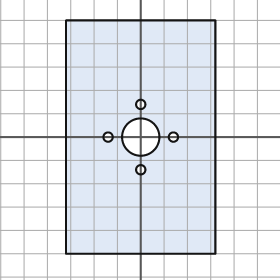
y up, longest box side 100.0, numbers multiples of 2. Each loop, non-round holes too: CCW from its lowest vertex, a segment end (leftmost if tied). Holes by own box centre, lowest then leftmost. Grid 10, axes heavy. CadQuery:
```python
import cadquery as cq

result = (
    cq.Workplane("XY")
    .moveTo(-32.0, -50.0)
    .lineTo(32.0, -50.0)
    .lineTo(32.0, 50.0)
    .lineTo(-32.0, 50.0)
    .close()
    .moveTo(0.0, -14.0)
    .circle(2.0)
    .moveTo(-14.0, 0.0)
    .circle(2.0)
    .moveTo(0.0, 0.0)
    .circle(8.0)
    .moveTo(14.0, 0.0)
    .circle(2.0)
    .moveTo(0.0, 14.0)
    .circle(2.0)
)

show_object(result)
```